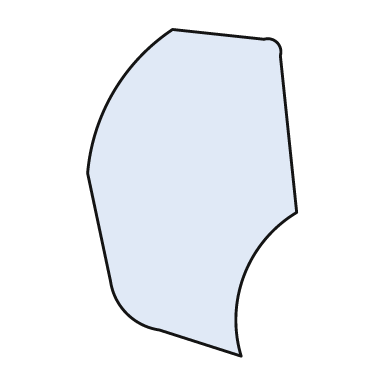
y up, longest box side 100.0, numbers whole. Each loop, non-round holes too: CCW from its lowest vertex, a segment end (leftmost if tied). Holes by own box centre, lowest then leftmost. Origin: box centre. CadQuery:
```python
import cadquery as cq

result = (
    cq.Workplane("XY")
    .moveTo(15.0, -50.0)
    .threePointArc((16.0, -25.0), (32.0, -6.0))
    .lineTo(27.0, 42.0)
    .threePointArc((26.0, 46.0), (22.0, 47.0))
    .lineTo(-6.0, 50.0)
    .threePointArc((-24.0, 31.0), (-32.0, 6.0))
    .lineTo(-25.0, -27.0)
    .threePointArc((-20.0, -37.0), (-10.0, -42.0))
    .close()
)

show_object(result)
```